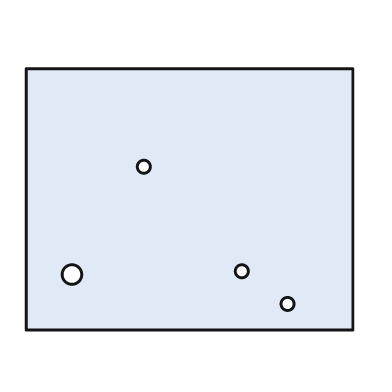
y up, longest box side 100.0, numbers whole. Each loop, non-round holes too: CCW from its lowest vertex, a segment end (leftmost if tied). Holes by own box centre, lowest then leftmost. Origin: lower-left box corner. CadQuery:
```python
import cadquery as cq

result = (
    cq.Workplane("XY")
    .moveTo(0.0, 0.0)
    .lineTo(100.0, 0.0)
    .lineTo(100.0, 80.0)
    .lineTo(0.0, 80.0)
    .close()
    .moveTo(80.0, 8.0)
    .circle(2.0)
    .moveTo(14.0, 17.0)
    .circle(3.0)
    .moveTo(66.0, 18.0)
    .circle(2.0)
    .moveTo(36.0, 50.0)
    .circle(2.0)
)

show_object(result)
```